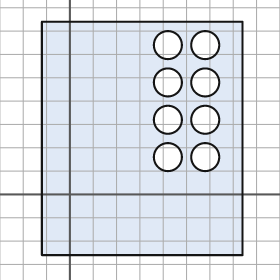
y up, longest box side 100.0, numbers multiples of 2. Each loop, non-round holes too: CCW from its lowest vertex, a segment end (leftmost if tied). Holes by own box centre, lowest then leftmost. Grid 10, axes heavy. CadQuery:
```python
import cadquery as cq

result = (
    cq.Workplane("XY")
    .moveTo(-12.0, -26.0)
    .lineTo(74.0, -26.0)
    .lineTo(74.0, 74.0)
    .lineTo(-12.0, 74.0)
    .close()
    .moveTo(42.0, 16.0)
    .circle(6.0)
    .moveTo(58.0, 16.0)
    .circle(6.0)
    .moveTo(42.0, 32.0)
    .circle(6.0)
    .moveTo(58.0, 32.0)
    .circle(6.0)
    .moveTo(42.0, 48.0)
    .circle(6.0)
    .moveTo(58.0, 48.0)
    .circle(6.0)
    .moveTo(42.0, 64.0)
    .circle(6.0)
    .moveTo(58.0, 64.0)
    .circle(6.0)
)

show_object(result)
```